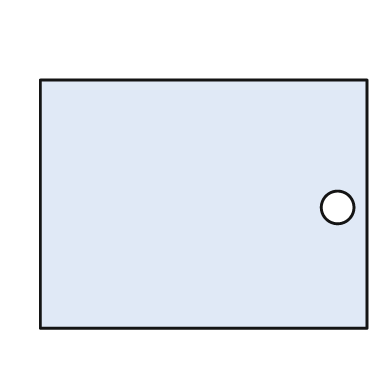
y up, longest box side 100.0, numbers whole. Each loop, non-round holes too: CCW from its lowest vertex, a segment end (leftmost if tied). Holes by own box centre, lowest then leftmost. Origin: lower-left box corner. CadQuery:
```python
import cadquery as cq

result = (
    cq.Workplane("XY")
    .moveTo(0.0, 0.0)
    .lineTo(100.0, 0.0)
    .lineTo(100.0, 76.0)
    .lineTo(0.0, 76.0)
    .close()
    .moveTo(91.0, 37.0)
    .circle(5.0)
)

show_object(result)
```